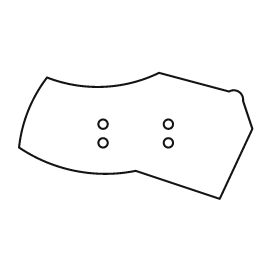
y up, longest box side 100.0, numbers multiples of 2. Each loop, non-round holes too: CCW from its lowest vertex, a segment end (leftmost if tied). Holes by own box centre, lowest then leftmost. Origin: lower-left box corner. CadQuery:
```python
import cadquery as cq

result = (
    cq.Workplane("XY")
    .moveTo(86.0, 0.0)
    .lineTo(100.0, 30.0)
    .lineTo(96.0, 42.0)
    .threePointArc((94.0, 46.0), (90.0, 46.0))
    .lineTo(60.0, 54.0)
    .threePointArc((36.0, 48.0), (12.0, 52.0))
    .threePointArc((4.0, 38.0), (0.0, 22.0))
    .threePointArc((24.0, 12.0), (50.0, 12.0))
    .close()
    .moveTo(36.0, 24.0)
    .circle(2.0)
    .moveTo(64.0, 24.0)
    .circle(2.0)
    .moveTo(36.0, 32.0)
    .circle(2.0)
    .moveTo(64.0, 32.0)
    .circle(2.0)
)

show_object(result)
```